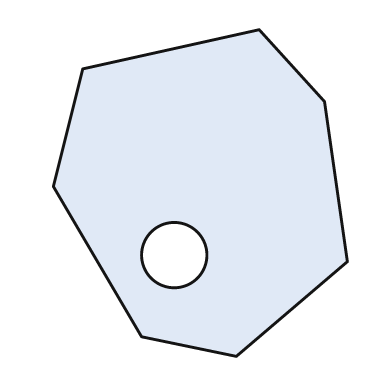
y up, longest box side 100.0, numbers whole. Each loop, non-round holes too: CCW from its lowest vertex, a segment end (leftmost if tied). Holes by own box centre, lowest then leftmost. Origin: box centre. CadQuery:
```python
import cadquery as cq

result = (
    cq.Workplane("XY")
    .moveTo(11.0, -50.0)
    .lineTo(45.0, -21.0)
    .lineTo(38.0, 28.0)
    .lineTo(18.0, 50.0)
    .lineTo(-36.0, 38.0)
    .lineTo(-45.0, 2.0)
    .lineTo(-18.0, -44.0)
    .close()
    .moveTo(-8.0, -19.0)
    .circle(10.0)
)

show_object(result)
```